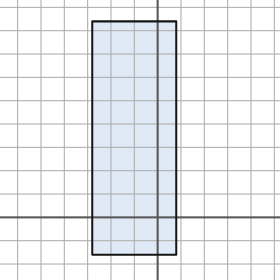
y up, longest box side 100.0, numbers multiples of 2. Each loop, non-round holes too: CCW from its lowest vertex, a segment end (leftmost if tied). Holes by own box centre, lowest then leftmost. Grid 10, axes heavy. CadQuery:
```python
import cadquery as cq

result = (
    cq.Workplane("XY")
    .moveTo(-28.0, -16.0)
    .lineTo(8.0, -16.0)
    .lineTo(8.0, 84.0)
    .lineTo(-28.0, 84.0)
    .close()
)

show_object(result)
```